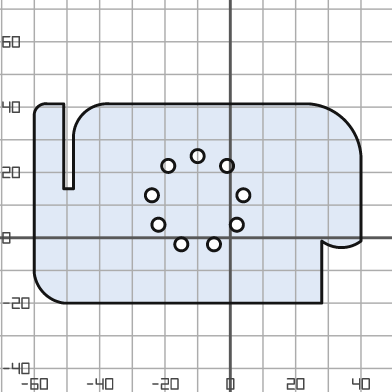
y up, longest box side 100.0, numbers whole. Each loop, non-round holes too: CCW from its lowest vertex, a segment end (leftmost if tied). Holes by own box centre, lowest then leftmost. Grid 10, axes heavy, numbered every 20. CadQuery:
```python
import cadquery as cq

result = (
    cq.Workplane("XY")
    .moveTo(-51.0, -20.0)
    .lineTo(28.0, -20.0)
    .lineTo(28.0, -1.0)
    .threePointArc((34.0, -3.0), (40.0, -1.0))
    .lineTo(40.0, 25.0)
    .threePointArc((35.0, 36.0), (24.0, 41.0))
    .lineTo(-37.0, 41.0)
    .threePointArc((-45.0, 38.0), (-48.0, 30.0))
    .lineTo(-48.0, 15.0)
    .lineTo(-51.0, 15.0)
    .lineTo(-51.0, 41.0)
    .lineTo(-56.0, 41.0)
    .threePointArc((-59.0, 40.0), (-60.0, 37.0))
    .lineTo(-60.0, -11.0)
    .threePointArc((-57.0, -17.0), (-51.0, -20.0))
    .close()
    .moveTo(-15.0, -2.0)
    .circle(2.0)
    .moveTo(-5.0, -2.0)
    .circle(2.0)
    .moveTo(-22.0, 4.0)
    .circle(2.0)
    .moveTo(2.0, 4.0)
    .circle(2.0)
    .moveTo(-24.0, 13.0)
    .circle(2.0)
    .moveTo(4.0, 13.0)
    .circle(2.0)
    .moveTo(-19.0, 22.0)
    .circle(2.0)
    .moveTo(-1.0, 22.0)
    .circle(2.0)
    .moveTo(-10.0, 25.0)
    .circle(2.0)
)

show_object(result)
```